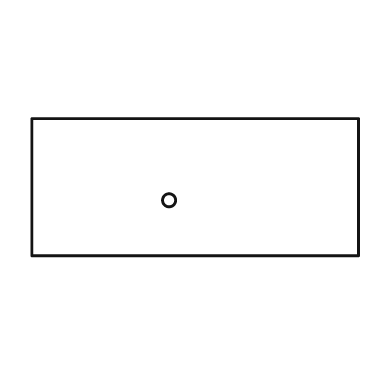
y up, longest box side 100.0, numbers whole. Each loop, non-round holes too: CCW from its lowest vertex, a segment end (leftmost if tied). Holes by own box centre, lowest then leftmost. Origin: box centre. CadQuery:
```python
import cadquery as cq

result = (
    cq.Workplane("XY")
    .moveTo(-50.0, -21.0)
    .lineTo(50.0, -21.0)
    .lineTo(50.0, 21.0)
    .lineTo(-50.0, 21.0)
    .close()
    .moveTo(-8.0, -4.0)
    .circle(2.0)
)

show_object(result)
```